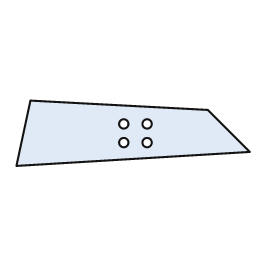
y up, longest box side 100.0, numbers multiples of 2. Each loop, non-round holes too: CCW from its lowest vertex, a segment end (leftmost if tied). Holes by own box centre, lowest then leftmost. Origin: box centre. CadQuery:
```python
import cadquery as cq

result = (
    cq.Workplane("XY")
    .moveTo(-50.0, -14.0)
    .lineTo(50.0, -8.0)
    .lineTo(32.0, 10.0)
    .lineTo(-44.0, 14.0)
    .close()
    .moveTo(-4.0, -4.0)
    .circle(2.0)
    .moveTo(6.0, -4.0)
    .circle(2.0)
    .moveTo(-4.0, 4.0)
    .circle(2.0)
    .moveTo(6.0, 4.0)
    .circle(2.0)
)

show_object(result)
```